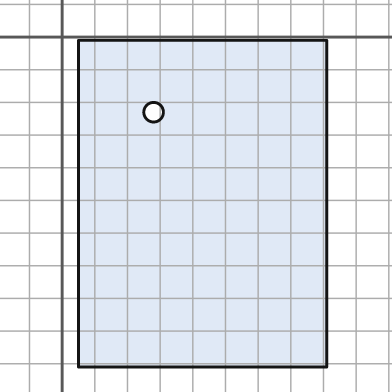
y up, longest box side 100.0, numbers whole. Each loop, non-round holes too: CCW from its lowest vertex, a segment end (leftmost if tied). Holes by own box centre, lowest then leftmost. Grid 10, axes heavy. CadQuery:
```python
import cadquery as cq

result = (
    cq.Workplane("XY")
    .moveTo(5.0, -101.0)
    .lineTo(81.0, -101.0)
    .lineTo(81.0, -1.0)
    .lineTo(5.0, -1.0)
    .close()
    .moveTo(28.0, -23.0)
    .circle(3.0)
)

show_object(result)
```